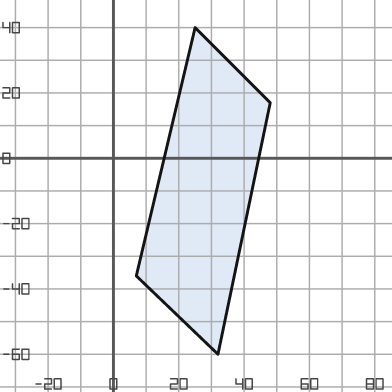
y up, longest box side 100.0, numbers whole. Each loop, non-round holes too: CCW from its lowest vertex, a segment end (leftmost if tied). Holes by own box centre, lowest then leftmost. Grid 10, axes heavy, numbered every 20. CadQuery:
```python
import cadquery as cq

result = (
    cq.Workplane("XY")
    .moveTo(32.0, -60.0)
    .lineTo(48.0, 17.0)
    .lineTo(25.0, 40.0)
    .lineTo(7.0, -36.0)
    .close()
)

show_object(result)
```